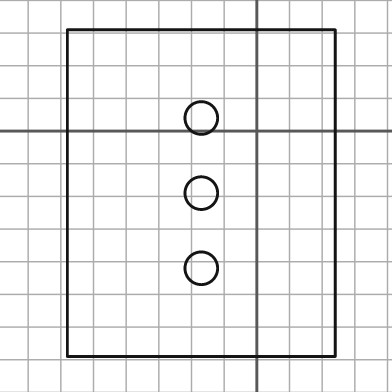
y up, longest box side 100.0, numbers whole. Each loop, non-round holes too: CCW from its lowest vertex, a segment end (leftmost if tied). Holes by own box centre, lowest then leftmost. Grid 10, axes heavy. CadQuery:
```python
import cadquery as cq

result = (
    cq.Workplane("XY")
    .moveTo(-58.0, -69.0)
    .lineTo(24.0, -69.0)
    .lineTo(24.0, 31.0)
    .lineTo(-58.0, 31.0)
    .close()
    .moveTo(-17.0, -42.0)
    .circle(5.0)
    .moveTo(-17.0, -19.0)
    .circle(5.0)
    .moveTo(-17.0, 4.0)
    .circle(5.0)
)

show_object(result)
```